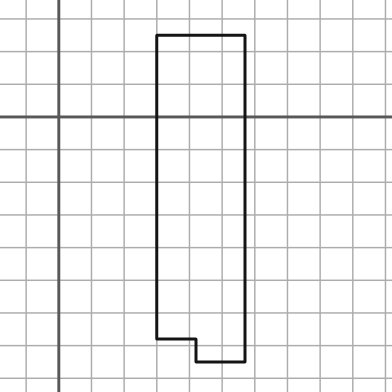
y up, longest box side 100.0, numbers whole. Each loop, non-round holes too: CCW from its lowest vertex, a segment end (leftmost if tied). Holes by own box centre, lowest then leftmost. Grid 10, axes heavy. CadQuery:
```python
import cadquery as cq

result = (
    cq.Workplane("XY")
    .moveTo(42.0, -75.0)
    .lineTo(57.0, -75.0)
    .lineTo(57.0, 25.0)
    .lineTo(30.0, 25.0)
    .lineTo(30.0, -68.0)
    .lineTo(42.0, -68.0)
    .close()
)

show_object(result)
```